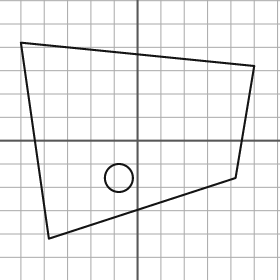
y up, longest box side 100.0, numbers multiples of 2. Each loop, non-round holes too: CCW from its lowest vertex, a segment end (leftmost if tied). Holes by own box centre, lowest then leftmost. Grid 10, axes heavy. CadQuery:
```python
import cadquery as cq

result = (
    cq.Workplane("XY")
    .moveTo(-38.0, -42.0)
    .lineTo(42.0, -16.0)
    .lineTo(50.0, 32.0)
    .lineTo(-50.0, 42.0)
    .close()
    .moveTo(-8.0, -16.0)
    .circle(6.0)
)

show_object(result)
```